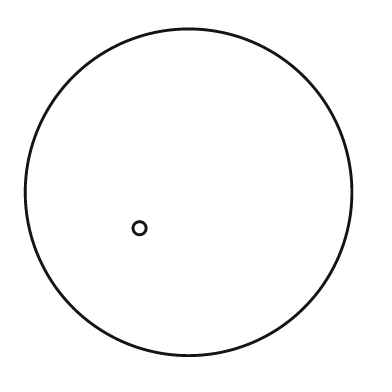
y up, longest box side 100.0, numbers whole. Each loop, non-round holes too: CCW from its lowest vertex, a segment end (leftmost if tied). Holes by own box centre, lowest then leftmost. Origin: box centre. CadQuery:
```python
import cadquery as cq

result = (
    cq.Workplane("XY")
    .moveTo(0.0, 0.0)
    .circle(50.0)
    .moveTo(-15.0, -11.0)
    .circle(2.0)
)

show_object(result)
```